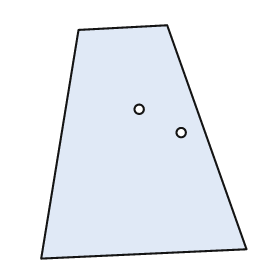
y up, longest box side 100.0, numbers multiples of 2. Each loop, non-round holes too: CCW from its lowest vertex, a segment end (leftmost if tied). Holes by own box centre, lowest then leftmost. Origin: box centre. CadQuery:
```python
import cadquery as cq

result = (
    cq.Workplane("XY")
    .moveTo(-44.0, -50.0)
    .lineTo(44.0, -46.0)
    .lineTo(10.0, 50.0)
    .lineTo(-28.0, 48.0)
    .close()
    .moveTo(16.0, 4.0)
    .circle(2.0)
    .moveTo(-2.0, 14.0)
    .circle(2.0)
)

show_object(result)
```